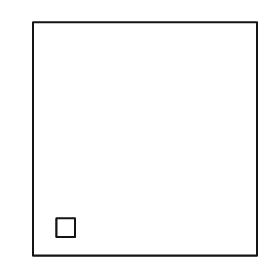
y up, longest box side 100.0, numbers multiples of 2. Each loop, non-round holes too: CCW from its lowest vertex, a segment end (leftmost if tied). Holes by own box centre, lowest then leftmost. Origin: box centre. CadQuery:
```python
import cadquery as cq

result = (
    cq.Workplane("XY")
    .moveTo(-48.0, -50.0)
    .lineTo(48.0, -50.0)
    .lineTo(48.0, 50.0)
    .lineTo(-48.0, 50.0)
    .close()
    .moveTo(-38.0, -42.0)
    .lineTo(-30.0, -42.0)
    .lineTo(-30.0, -34.0)
    .lineTo(-38.0, -34.0)
    .close()
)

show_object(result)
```